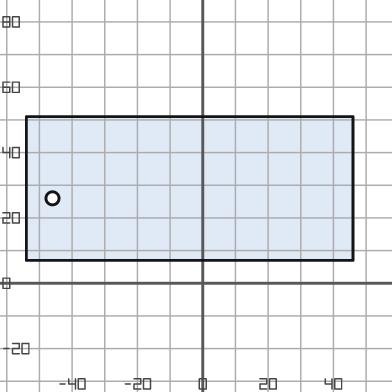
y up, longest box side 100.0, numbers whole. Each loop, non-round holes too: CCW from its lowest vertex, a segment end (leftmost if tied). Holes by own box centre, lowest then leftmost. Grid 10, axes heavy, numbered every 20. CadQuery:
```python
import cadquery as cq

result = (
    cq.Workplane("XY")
    .moveTo(-54.0, 7.0)
    .lineTo(46.0, 7.0)
    .lineTo(46.0, 51.0)
    .lineTo(-54.0, 51.0)
    .close()
    .moveTo(-46.0, 26.0)
    .circle(2.0)
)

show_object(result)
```